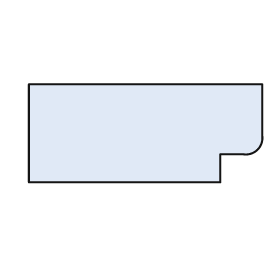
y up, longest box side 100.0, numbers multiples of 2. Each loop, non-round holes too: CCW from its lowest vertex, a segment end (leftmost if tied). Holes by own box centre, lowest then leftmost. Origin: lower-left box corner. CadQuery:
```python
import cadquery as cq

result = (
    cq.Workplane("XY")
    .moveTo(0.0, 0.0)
    .lineTo(82.0, 0.0)
    .lineTo(82.0, 12.0)
    .lineTo(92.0, 12.0)
    .threePointArc((98.0, 14.0), (100.0, 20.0))
    .lineTo(100.0, 42.0)
    .lineTo(0.0, 42.0)
    .close()
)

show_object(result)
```